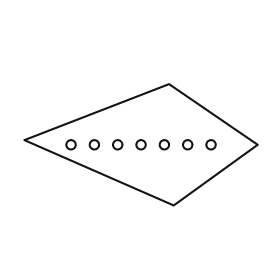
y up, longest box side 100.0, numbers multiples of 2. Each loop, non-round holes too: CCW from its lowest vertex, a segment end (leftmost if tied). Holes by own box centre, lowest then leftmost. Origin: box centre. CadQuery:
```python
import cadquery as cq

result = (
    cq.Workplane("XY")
    .moveTo(14.0, -26.0)
    .lineTo(50.0, 0.0)
    .lineTo(12.0, 26.0)
    .lineTo(-50.0, 2.0)
    .close()
    .moveTo(-30.0, 0.0)
    .circle(2.0)
    .moveTo(-20.0, 0.0)
    .circle(2.0)
    .moveTo(-10.0, 0.0)
    .circle(2.0)
    .moveTo(0.0, 0.0)
    .circle(2.0)
    .moveTo(10.0, 0.0)
    .circle(2.0)
    .moveTo(20.0, 0.0)
    .circle(2.0)
    .moveTo(30.0, 0.0)
    .circle(2.0)
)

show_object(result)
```